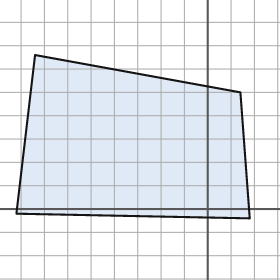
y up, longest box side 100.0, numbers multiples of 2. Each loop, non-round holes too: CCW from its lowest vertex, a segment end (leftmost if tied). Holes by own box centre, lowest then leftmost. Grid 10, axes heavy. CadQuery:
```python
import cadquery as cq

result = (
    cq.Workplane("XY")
    .moveTo(18.0, -4.0)
    .lineTo(14.0, 50.0)
    .lineTo(-74.0, 66.0)
    .lineTo(-82.0, -2.0)
    .close()
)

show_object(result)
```